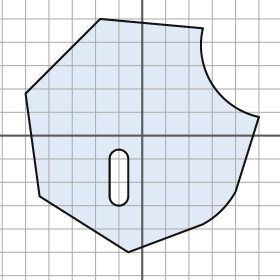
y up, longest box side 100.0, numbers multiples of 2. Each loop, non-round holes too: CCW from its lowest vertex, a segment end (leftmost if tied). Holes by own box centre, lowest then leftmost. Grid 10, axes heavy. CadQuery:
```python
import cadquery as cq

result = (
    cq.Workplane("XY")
    .moveTo(-6.0, -50.0)
    .lineTo(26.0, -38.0)
    .threePointArc((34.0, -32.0), (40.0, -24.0))
    .lineTo(50.0, 8.0)
    .threePointArc((30.0, 22.0), (26.0, 46.0))
    .lineTo(-18.0, 50.0)
    .lineTo(-50.0, 18.0)
    .lineTo(-44.0, -26.0)
    .close()
    .moveTo(-14.0, -26.0)
    .threePointArc((-10.0, -30.0), (-6.0, -26.0))
    .lineTo(-6.0, -10.0)
    .threePointArc((-10.0, -6.0), (-14.0, -10.0))
    .close()
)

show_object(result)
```